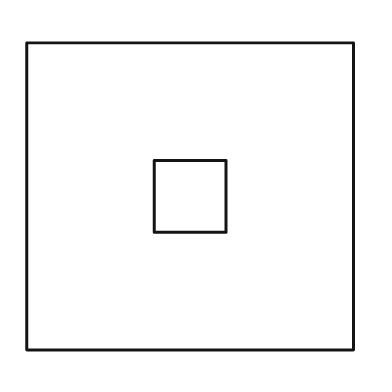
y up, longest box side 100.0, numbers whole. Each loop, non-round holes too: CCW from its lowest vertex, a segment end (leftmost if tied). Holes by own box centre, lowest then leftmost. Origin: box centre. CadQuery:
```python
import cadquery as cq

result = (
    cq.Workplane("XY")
    .moveTo(-50.0, -47.0)
    .lineTo(50.0, -47.0)
    .lineTo(50.0, 47.0)
    .lineTo(-50.0, 47.0)
    .close()
    .moveTo(-11.0, -11.0)
    .lineTo(11.0, -11.0)
    .lineTo(11.0, 11.0)
    .lineTo(-11.0, 11.0)
    .close()
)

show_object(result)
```